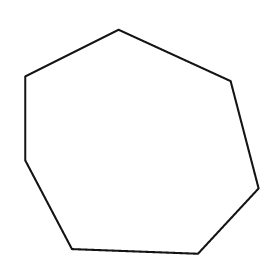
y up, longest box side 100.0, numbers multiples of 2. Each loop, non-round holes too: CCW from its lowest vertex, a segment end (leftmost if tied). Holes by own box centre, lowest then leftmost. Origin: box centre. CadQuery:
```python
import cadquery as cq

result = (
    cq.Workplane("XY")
    .moveTo(24.0, -48.0)
    .lineTo(50.0, -20.0)
    .lineTo(38.0, 26.0)
    .lineTo(-10.0, 48.0)
    .lineTo(-50.0, 28.0)
    .lineTo(-50.0, -8.0)
    .lineTo(-30.0, -46.0)
    .close()
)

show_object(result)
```